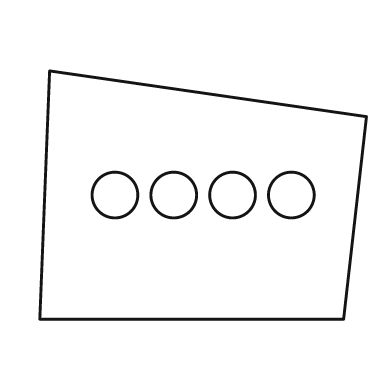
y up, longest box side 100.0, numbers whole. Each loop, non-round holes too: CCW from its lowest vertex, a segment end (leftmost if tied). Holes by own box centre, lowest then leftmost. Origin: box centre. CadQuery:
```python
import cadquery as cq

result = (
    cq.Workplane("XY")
    .moveTo(-50.0, -38.0)
    .lineTo(43.0, -38.0)
    .lineTo(50.0, 24.0)
    .lineTo(-47.0, 38.0)
    .close()
    .moveTo(-27.0, 0.0)
    .circle(7.0)
    .moveTo(-9.0, 0.0)
    .circle(7.0)
    .moveTo(9.0, 0.0)
    .circle(7.0)
    .moveTo(27.0, 0.0)
    .circle(7.0)
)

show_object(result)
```